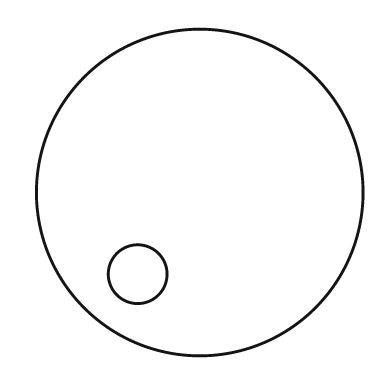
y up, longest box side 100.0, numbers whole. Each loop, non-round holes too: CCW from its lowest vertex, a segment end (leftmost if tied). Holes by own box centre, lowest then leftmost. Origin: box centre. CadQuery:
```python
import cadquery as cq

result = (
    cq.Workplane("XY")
    .moveTo(0.0, 0.0)
    .circle(50.0)
    .moveTo(-19.0, -25.0)
    .circle(9.0)
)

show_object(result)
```